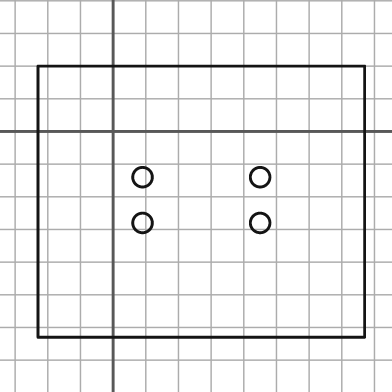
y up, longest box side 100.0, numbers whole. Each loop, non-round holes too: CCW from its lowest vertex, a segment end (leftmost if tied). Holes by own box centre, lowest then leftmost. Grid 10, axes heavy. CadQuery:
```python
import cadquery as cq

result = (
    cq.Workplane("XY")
    .moveTo(-23.0, -63.0)
    .lineTo(77.0, -63.0)
    .lineTo(77.0, 20.0)
    .lineTo(-23.0, 20.0)
    .close()
    .moveTo(9.0, -28.0)
    .circle(3.0)
    .moveTo(45.0, -28.0)
    .circle(3.0)
    .moveTo(9.0, -14.0)
    .circle(3.0)
    .moveTo(45.0, -14.0)
    .circle(3.0)
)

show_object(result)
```